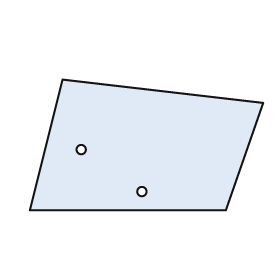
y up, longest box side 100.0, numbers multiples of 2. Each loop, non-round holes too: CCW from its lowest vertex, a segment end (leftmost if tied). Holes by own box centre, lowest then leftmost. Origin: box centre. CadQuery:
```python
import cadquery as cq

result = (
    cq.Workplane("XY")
    .moveTo(-50.0, -28.0)
    .lineTo(34.0, -28.0)
    .lineTo(50.0, 18.0)
    .lineTo(-36.0, 28.0)
    .close()
    .moveTo(-2.0, -20.0)
    .circle(2.0)
    .moveTo(-28.0, -2.0)
    .circle(2.0)
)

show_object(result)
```